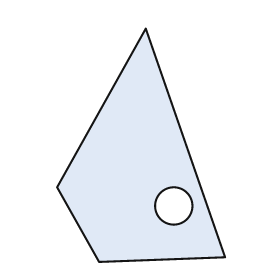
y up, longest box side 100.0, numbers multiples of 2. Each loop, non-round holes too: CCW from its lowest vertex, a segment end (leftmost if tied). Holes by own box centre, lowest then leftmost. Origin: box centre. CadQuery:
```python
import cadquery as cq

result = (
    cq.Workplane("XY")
    .moveTo(-18.0, -50.0)
    .lineTo(36.0, -48.0)
    .lineTo(2.0, 50.0)
    .lineTo(-36.0, -18.0)
    .close()
    .moveTo(14.0, -26.0)
    .circle(8.0)
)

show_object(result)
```